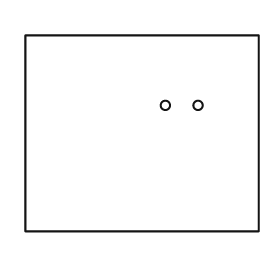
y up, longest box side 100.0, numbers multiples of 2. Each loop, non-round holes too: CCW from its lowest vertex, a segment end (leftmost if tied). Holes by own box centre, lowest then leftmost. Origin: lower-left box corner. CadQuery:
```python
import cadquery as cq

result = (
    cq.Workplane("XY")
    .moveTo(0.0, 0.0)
    .lineTo(100.0, 0.0)
    .lineTo(100.0, 84.0)
    .lineTo(0.0, 84.0)
    .close()
    .moveTo(60.0, 54.0)
    .circle(2.0)
    .moveTo(74.0, 54.0)
    .circle(2.0)
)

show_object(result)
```